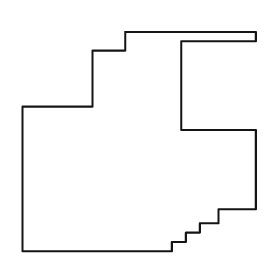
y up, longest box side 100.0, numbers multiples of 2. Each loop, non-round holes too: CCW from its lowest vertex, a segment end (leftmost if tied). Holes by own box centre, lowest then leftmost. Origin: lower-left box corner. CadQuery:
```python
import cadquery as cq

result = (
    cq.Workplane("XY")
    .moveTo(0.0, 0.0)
    .lineTo(64.0, 0.0)
    .lineTo(64.0, 4.0)
    .lineTo(70.0, 4.0)
    .lineTo(70.0, 8.0)
    .lineTo(76.0, 8.0)
    .lineTo(76.0, 12.0)
    .lineTo(84.0, 12.0)
    .lineTo(84.0, 18.0)
    .lineTo(100.0, 18.0)
    .lineTo(100.0, 52.0)
    .lineTo(68.0, 52.0)
    .lineTo(68.0, 90.0)
    .lineTo(100.0, 90.0)
    .lineTo(100.0, 94.0)
    .lineTo(44.0, 94.0)
    .lineTo(44.0, 86.0)
    .lineTo(30.0, 86.0)
    .lineTo(30.0, 62.0)
    .lineTo(0.0, 62.0)
    .close()
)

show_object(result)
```